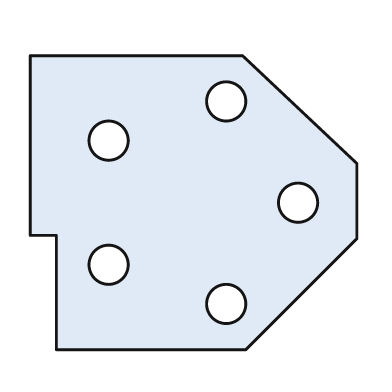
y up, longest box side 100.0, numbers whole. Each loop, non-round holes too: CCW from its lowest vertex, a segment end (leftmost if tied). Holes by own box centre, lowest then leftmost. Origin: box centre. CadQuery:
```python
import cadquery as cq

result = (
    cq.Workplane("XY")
    .moveTo(-42.0, -45.0)
    .lineTo(16.0, -45.0)
    .lineTo(50.0, -11.0)
    .lineTo(50.0, 12.0)
    .lineTo(15.0, 45.0)
    .lineTo(-50.0, 45.0)
    .lineTo(-50.0, -10.0)
    .lineTo(-42.0, -10.0)
    .close()
    .moveTo(10.0, -31.0)
    .circle(6.0)
    .moveTo(-26.0, -19.0)
    .circle(6.0)
    .moveTo(32.0, 0.0)
    .circle(6.0)
    .moveTo(-26.0, 19.0)
    .circle(6.0)
    .moveTo(10.0, 31.0)
    .circle(6.0)
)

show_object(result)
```